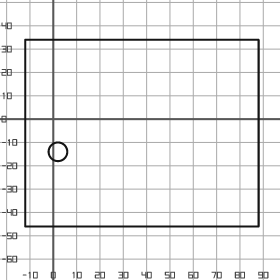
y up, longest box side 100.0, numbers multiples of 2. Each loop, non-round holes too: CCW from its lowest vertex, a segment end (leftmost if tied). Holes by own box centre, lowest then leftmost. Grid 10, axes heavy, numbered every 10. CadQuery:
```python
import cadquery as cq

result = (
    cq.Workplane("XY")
    .moveTo(-12.0, -46.0)
    .lineTo(88.0, -46.0)
    .lineTo(88.0, 34.0)
    .lineTo(-12.0, 34.0)
    .close()
    .moveTo(2.0, -14.0)
    .circle(4.0)
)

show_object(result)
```